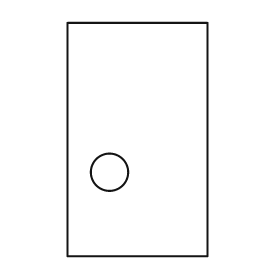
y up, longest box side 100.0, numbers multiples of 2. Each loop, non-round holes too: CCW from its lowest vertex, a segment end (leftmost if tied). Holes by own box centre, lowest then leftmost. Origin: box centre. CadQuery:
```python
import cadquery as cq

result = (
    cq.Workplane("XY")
    .moveTo(-30.0, -50.0)
    .lineTo(30.0, -50.0)
    .lineTo(30.0, 50.0)
    .lineTo(-30.0, 50.0)
    .close()
    .moveTo(-12.0, -14.0)
    .circle(8.0)
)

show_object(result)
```